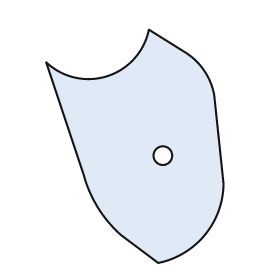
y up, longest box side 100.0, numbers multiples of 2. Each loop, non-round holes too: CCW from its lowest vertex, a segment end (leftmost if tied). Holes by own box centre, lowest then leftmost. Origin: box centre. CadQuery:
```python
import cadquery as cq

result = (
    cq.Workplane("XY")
    .moveTo(10.0, -50.0)
    .threePointArc((30.0, -38.0), (38.0, -16.0))
    .lineTo(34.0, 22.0)
    .threePointArc((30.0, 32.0), (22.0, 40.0))
    .lineTo(6.0, 50.0)
    .threePointArc((-12.0, 30.0), (-38.0, 36.0))
    .lineTo(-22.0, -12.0)
    .threePointArc((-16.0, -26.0), (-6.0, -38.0))
    .close()
    .moveTo(12.0, -4.0)
    .circle(4.0)
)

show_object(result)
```